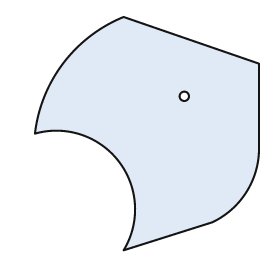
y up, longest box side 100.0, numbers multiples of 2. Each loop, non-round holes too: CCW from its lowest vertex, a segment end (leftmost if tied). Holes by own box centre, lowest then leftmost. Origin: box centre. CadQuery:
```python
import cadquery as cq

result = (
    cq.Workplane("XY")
    .moveTo(-10.0, -50.0)
    .lineTo(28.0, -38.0)
    .threePointArc((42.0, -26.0), (48.0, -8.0))
    .lineTo(48.0, 30.0)
    .lineTo(-10.0, 50.0)
    .threePointArc((-36.0, 30.0), (-48.0, 0.0))
    .threePointArc((-12.0, -12.0), (-10.0, -50.0))
    .close()
    .moveTo(16.0, 16.0)
    .circle(2.0)
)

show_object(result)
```